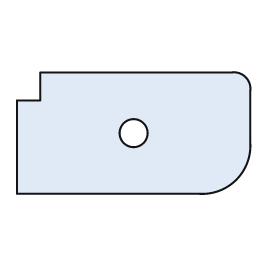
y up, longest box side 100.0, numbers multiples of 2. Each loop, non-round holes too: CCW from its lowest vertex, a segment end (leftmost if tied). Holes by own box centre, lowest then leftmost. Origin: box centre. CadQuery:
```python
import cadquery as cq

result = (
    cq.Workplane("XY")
    .moveTo(-50.0, -26.0)
    .lineTo(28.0, -26.0)
    .threePointArc((44.0, -20.0), (50.0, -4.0))
    .lineTo(50.0, 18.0)
    .threePointArc((48.0, 24.0), (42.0, 26.0))
    .lineTo(-40.0, 26.0)
    .lineTo(-40.0, 14.0)
    .lineTo(-50.0, 14.0)
    .close()
    .moveTo(0.0, 0.0)
    .circle(6.0)
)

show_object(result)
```